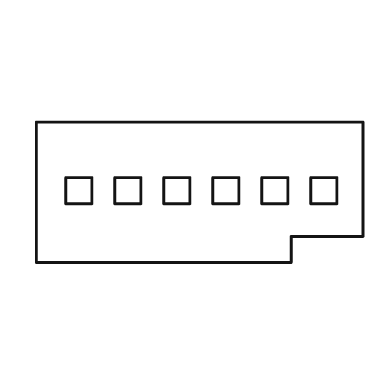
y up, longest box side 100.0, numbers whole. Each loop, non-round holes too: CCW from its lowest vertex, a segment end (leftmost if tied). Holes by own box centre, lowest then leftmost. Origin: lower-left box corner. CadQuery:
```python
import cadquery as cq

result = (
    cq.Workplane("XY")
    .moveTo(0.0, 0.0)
    .lineTo(78.0, 0.0)
    .lineTo(78.0, 8.0)
    .lineTo(100.0, 8.0)
    .lineTo(100.0, 43.0)
    .lineTo(0.0, 43.0)
    .close()
    .moveTo(9.0, 18.0)
    .lineTo(17.0, 18.0)
    .lineTo(17.0, 26.0)
    .lineTo(9.0, 26.0)
    .close()
    .moveTo(24.0, 18.0)
    .lineTo(32.0, 18.0)
    .lineTo(32.0, 26.0)
    .lineTo(24.0, 26.0)
    .close()
    .moveTo(39.0, 18.0)
    .lineTo(47.0, 18.0)
    .lineTo(47.0, 26.0)
    .lineTo(39.0, 26.0)
    .close()
    .moveTo(54.0, 18.0)
    .lineTo(62.0, 18.0)
    .lineTo(62.0, 26.0)
    .lineTo(54.0, 26.0)
    .close()
    .moveTo(69.0, 18.0)
    .lineTo(77.0, 18.0)
    .lineTo(77.0, 26.0)
    .lineTo(69.0, 26.0)
    .close()
    .moveTo(84.0, 18.0)
    .lineTo(92.0, 18.0)
    .lineTo(92.0, 26.0)
    .lineTo(84.0, 26.0)
    .close()
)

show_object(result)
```